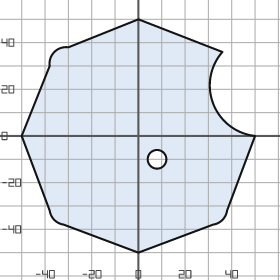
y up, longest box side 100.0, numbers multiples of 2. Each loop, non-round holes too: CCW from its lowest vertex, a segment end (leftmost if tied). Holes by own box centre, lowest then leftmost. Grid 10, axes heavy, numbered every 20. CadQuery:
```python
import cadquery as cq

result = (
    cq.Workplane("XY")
    .moveTo(0.0, -50.0)
    .lineTo(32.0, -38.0)
    .threePointArc((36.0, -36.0), (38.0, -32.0))
    .lineTo(50.0, 0.0)
    .threePointArc((32.0, 14.0), (36.0, 36.0))
    .lineTo(0.0, 50.0)
    .lineTo(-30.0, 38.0)
    .threePointArc((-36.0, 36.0), (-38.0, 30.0))
    .lineTo(-50.0, 0.0)
    .lineTo(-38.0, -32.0)
    .threePointArc((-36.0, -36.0), (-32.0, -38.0))
    .close()
    .moveTo(8.0, -10.0)
    .circle(4.0)
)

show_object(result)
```